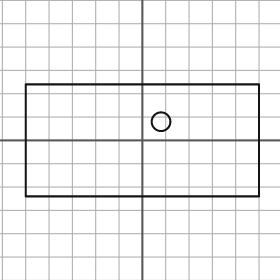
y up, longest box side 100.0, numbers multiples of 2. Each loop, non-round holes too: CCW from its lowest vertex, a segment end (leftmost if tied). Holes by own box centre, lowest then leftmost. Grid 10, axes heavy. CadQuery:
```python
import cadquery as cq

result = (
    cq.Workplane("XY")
    .moveTo(-50.0, -24.0)
    .lineTo(50.0, -24.0)
    .lineTo(50.0, 24.0)
    .lineTo(-50.0, 24.0)
    .close()
    .moveTo(8.0, 8.0)
    .circle(4.0)
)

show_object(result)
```